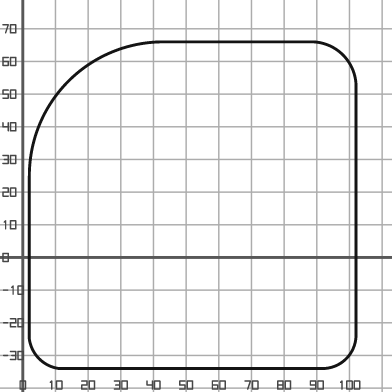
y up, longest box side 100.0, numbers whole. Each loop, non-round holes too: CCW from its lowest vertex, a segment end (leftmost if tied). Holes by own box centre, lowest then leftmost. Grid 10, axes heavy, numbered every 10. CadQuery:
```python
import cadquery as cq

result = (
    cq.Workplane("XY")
    .moveTo(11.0, -34.0)
    .lineTo(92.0, -34.0)
    .threePointArc((99.0, -31.0), (102.0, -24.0))
    .lineTo(102.0, 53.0)
    .threePointArc((98.0, 62.0), (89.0, 66.0))
    .lineTo(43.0, 66.0)
    .threePointArc((14.0, 54.0), (2.0, 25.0))
    .lineTo(2.0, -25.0)
    .threePointArc((5.0, -31.0), (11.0, -34.0))
    .close()
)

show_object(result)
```